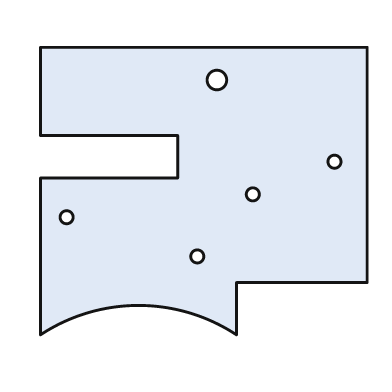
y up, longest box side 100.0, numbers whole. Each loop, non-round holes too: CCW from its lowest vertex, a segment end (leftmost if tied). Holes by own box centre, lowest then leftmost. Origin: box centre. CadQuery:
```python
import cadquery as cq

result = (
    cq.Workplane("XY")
    .moveTo(-50.0, -44.0)
    .threePointArc((-20.0, -35.0), (10.0, -44.0))
    .lineTo(10.0, -28.0)
    .lineTo(50.0, -28.0)
    .lineTo(50.0, 44.0)
    .lineTo(-50.0, 44.0)
    .lineTo(-50.0, 17.0)
    .lineTo(-8.0, 17.0)
    .lineTo(-8.0, 4.0)
    .lineTo(-50.0, 4.0)
    .close()
    .moveTo(-2.0, -20.0)
    .circle(2.0)
    .moveTo(-42.0, -8.0)
    .circle(2.0)
    .moveTo(15.0, -1.0)
    .circle(2.0)
    .moveTo(40.0, 9.0)
    .circle(2.0)
    .moveTo(4.0, 34.0)
    .circle(3.0)
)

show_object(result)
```